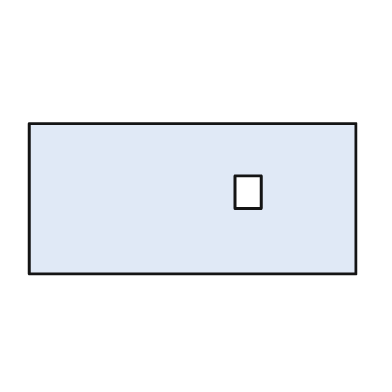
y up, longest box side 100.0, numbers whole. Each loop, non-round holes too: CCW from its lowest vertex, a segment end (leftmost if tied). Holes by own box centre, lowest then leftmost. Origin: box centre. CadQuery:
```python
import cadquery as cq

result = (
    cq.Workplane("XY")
    .moveTo(-50.0, -23.0)
    .lineTo(50.0, -23.0)
    .lineTo(50.0, 23.0)
    .lineTo(-50.0, 23.0)
    .close()
    .moveTo(13.0, -3.0)
    .lineTo(21.0, -3.0)
    .lineTo(21.0, 7.0)
    .lineTo(13.0, 7.0)
    .close()
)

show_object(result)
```